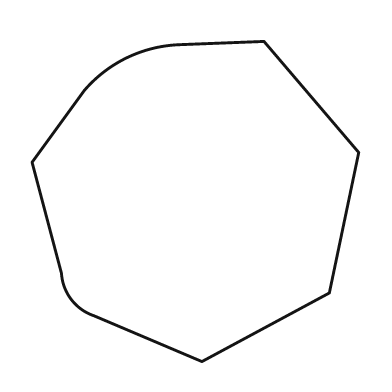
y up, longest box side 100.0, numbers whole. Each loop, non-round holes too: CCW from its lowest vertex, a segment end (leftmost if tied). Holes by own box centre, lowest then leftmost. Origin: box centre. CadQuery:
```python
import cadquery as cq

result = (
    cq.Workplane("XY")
    .moveTo(2.0, -49.0)
    .lineTo(41.0, -28.0)
    .lineTo(50.0, 15.0)
    .lineTo(21.0, 49.0)
    .lineTo(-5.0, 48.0)
    .threePointArc((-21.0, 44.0), (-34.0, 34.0))
    .lineTo(-50.0, 12.0)
    .lineTo(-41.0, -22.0)
    .threePointArc((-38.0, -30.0), (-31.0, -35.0))
    .close()
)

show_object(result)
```